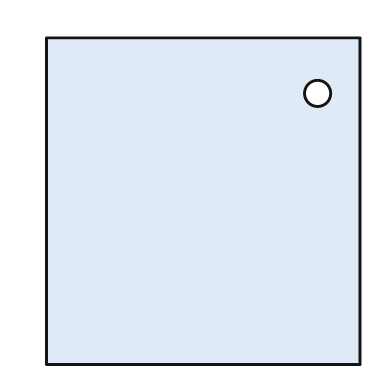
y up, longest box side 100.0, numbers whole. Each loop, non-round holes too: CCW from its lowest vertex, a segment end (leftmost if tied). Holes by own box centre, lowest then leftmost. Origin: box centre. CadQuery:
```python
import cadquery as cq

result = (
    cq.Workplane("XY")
    .moveTo(-48.0, -50.0)
    .lineTo(48.0, -50.0)
    .lineTo(48.0, 50.0)
    .lineTo(-48.0, 50.0)
    .close()
    .moveTo(35.0, 33.0)
    .circle(4.0)
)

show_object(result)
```